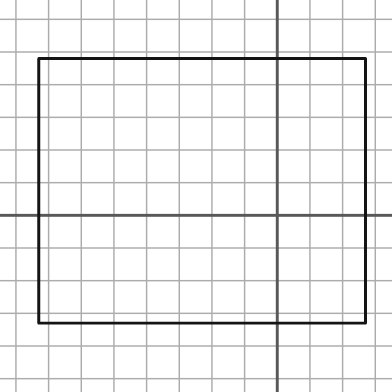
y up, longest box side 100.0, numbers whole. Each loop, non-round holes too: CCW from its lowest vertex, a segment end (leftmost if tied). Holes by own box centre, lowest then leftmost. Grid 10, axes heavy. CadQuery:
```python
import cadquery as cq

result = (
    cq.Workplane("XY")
    .moveTo(-73.0, -33.0)
    .lineTo(27.0, -33.0)
    .lineTo(27.0, 48.0)
    .lineTo(-73.0, 48.0)
    .close()
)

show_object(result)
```